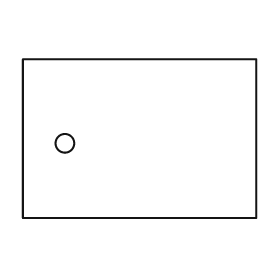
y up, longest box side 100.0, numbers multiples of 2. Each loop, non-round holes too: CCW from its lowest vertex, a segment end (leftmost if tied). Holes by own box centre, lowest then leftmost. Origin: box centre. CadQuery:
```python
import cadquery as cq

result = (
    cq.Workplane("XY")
    .moveTo(-50.0, -34.0)
    .lineTo(50.0, -34.0)
    .lineTo(50.0, 34.0)
    .lineTo(-50.0, 34.0)
    .close()
    .moveTo(-32.0, -2.0)
    .circle(4.0)
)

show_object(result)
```